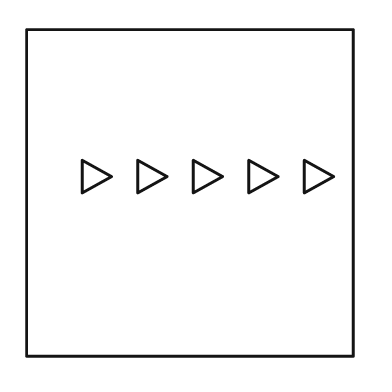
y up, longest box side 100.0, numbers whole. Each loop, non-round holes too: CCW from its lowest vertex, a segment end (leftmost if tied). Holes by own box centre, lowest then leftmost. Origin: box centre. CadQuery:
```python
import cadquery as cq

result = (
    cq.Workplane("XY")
    .moveTo(-50.0, -50.0)
    .lineTo(50.0, -50.0)
    .lineTo(50.0, 50.0)
    .lineTo(-50.0, 50.0)
    .close()
    .moveTo(-33.0, 0.0)
    .lineTo(-24.0, 5.0)
    .lineTo(-33.0, 10.0)
    .close()
    .moveTo(-16.0, 0.0)
    .lineTo(-7.0, 5.0)
    .lineTo(-16.0, 10.0)
    .close()
    .moveTo(1.0, 0.0)
    .lineTo(10.0, 5.0)
    .lineTo(1.0, 10.0)
    .close()
    .moveTo(18.0, 0.0)
    .lineTo(27.0, 5.0)
    .lineTo(18.0, 10.0)
    .close()
    .moveTo(35.0, 0.0)
    .lineTo(44.0, 5.0)
    .lineTo(35.0, 10.0)
    .close()
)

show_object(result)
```